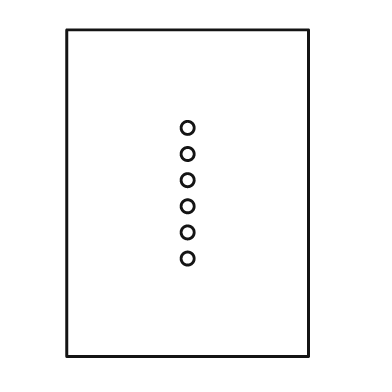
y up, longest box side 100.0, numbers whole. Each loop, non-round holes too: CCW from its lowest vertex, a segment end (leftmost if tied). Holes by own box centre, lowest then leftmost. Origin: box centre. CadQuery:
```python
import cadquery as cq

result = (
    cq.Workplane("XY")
    .moveTo(-37.0, -50.0)
    .lineTo(37.0, -50.0)
    .lineTo(37.0, 50.0)
    .lineTo(-37.0, 50.0)
    .close()
    .moveTo(0.0, -20.0)
    .circle(2.0)
    .moveTo(0.0, -12.0)
    .circle(2.0)
    .moveTo(0.0, -4.0)
    .circle(2.0)
    .moveTo(0.0, 4.0)
    .circle(2.0)
    .moveTo(0.0, 12.0)
    .circle(2.0)
    .moveTo(0.0, 20.0)
    .circle(2.0)
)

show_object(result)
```